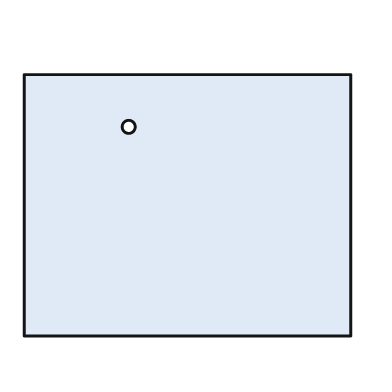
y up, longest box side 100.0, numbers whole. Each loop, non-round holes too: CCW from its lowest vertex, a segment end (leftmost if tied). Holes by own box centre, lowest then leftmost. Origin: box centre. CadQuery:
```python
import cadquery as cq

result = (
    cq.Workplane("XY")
    .moveTo(-50.0, -40.0)
    .lineTo(50.0, -40.0)
    .lineTo(50.0, 40.0)
    .lineTo(-50.0, 40.0)
    .close()
    .moveTo(-18.0, 24.0)
    .circle(2.0)
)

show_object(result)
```